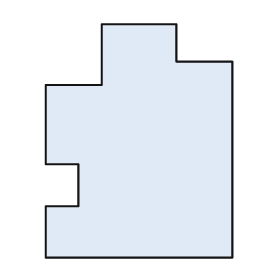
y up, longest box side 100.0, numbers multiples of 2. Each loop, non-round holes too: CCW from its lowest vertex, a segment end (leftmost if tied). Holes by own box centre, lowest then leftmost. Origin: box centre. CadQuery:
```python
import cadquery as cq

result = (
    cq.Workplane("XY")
    .moveTo(-40.0, -50.0)
    .lineTo(40.0, -50.0)
    .lineTo(40.0, 34.0)
    .lineTo(16.0, 34.0)
    .lineTo(16.0, 50.0)
    .lineTo(-16.0, 50.0)
    .lineTo(-16.0, 24.0)
    .lineTo(-40.0, 24.0)
    .lineTo(-40.0, -10.0)
    .lineTo(-26.0, -10.0)
    .lineTo(-26.0, -28.0)
    .lineTo(-40.0, -28.0)
    .close()
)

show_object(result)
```